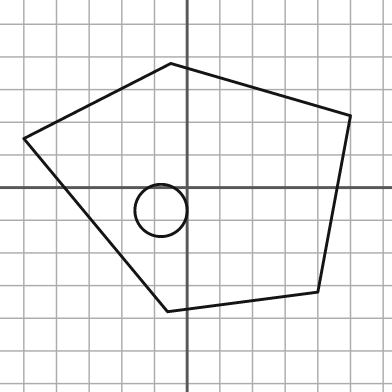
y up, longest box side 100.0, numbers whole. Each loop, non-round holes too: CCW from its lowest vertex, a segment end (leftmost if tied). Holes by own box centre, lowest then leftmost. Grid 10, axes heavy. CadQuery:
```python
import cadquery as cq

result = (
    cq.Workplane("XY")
    .moveTo(-6.0, -38.0)
    .lineTo(40.0, -32.0)
    .lineTo(50.0, 22.0)
    .lineTo(-5.0, 38.0)
    .lineTo(-50.0, 15.0)
    .close()
    .moveTo(-8.0, -7.0)
    .circle(8.0)
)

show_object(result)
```